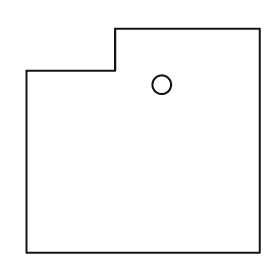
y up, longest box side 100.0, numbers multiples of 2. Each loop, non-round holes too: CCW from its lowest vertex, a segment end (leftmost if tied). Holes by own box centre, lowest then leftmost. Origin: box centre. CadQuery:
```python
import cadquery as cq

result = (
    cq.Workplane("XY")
    .moveTo(-50.0, -48.0)
    .lineTo(50.0, -48.0)
    .lineTo(50.0, 48.0)
    .lineTo(-12.0, 48.0)
    .lineTo(-12.0, 30.0)
    .lineTo(-50.0, 30.0)
    .close()
    .moveTo(8.0, 24.0)
    .circle(4.0)
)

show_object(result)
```